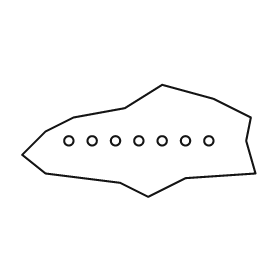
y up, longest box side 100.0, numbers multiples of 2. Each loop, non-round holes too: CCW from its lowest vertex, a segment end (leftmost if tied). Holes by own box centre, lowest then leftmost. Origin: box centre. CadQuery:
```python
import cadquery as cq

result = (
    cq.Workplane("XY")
    .moveTo(4.0, -24.0)
    .lineTo(20.0, -16.0)
    .lineTo(50.0, -14.0)
    .lineTo(46.0, 0.0)
    .lineTo(48.0, 10.0)
    .lineTo(32.0, 18.0)
    .lineTo(10.0, 24.0)
    .lineTo(-6.0, 14.0)
    .lineTo(-28.0, 10.0)
    .lineTo(-40.0, 4.0)
    .lineTo(-50.0, -6.0)
    .lineTo(-40.0, -14.0)
    .lineTo(-8.0, -18.0)
    .close()
    .moveTo(-30.0, 0.0)
    .circle(2.0)
    .moveTo(-20.0, 0.0)
    .circle(2.0)
    .moveTo(-10.0, 0.0)
    .circle(2.0)
    .moveTo(0.0, 0.0)
    .circle(2.0)
    .moveTo(10.0, 0.0)
    .circle(2.0)
    .moveTo(20.0, 0.0)
    .circle(2.0)
    .moveTo(30.0, 0.0)
    .circle(2.0)
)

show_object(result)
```